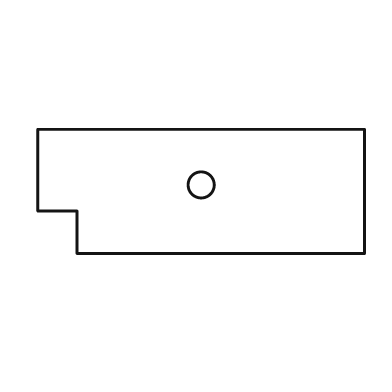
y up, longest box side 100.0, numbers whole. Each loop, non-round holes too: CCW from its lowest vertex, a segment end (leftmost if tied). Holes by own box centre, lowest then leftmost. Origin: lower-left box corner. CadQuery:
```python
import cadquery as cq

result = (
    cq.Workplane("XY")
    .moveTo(12.0, 0.0)
    .lineTo(100.0, 0.0)
    .lineTo(100.0, 38.0)
    .lineTo(0.0, 38.0)
    .lineTo(0.0, 13.0)
    .lineTo(12.0, 13.0)
    .close()
    .moveTo(50.0, 21.0)
    .circle(4.0)
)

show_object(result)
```